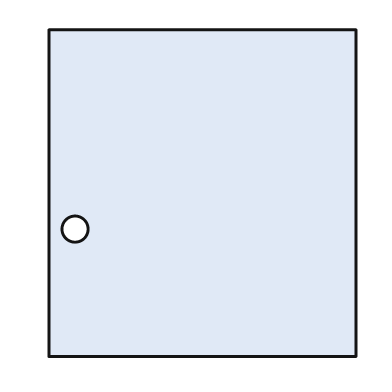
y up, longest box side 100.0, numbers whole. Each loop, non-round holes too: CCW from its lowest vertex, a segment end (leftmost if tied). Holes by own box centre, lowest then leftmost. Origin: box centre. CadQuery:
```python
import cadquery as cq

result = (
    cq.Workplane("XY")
    .moveTo(-47.0, -50.0)
    .lineTo(47.0, -50.0)
    .lineTo(47.0, 50.0)
    .lineTo(-47.0, 50.0)
    .close()
    .moveTo(-39.0, -11.0)
    .circle(4.0)
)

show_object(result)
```